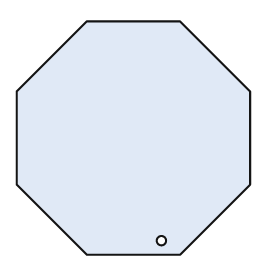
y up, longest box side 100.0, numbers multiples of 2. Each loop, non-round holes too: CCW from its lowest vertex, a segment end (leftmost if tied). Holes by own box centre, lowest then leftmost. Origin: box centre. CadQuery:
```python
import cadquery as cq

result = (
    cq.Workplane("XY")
    .moveTo(-20.0, -50.0)
    .lineTo(20.0, -50.0)
    .lineTo(50.0, -20.0)
    .lineTo(50.0, 20.0)
    .lineTo(20.0, 50.0)
    .lineTo(-20.0, 50.0)
    .lineTo(-50.0, 20.0)
    .lineTo(-50.0, -20.0)
    .close()
    .moveTo(12.0, -44.0)
    .circle(2.0)
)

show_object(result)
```